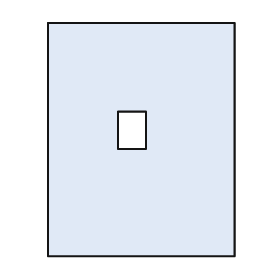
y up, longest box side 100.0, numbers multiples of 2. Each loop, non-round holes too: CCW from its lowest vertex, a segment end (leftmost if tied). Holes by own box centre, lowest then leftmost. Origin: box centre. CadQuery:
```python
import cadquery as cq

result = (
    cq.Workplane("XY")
    .moveTo(-40.0, -50.0)
    .lineTo(40.0, -50.0)
    .lineTo(40.0, 50.0)
    .lineTo(-40.0, 50.0)
    .close()
    .moveTo(-10.0, -4.0)
    .lineTo(2.0, -4.0)
    .lineTo(2.0, 12.0)
    .lineTo(-10.0, 12.0)
    .close()
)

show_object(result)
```